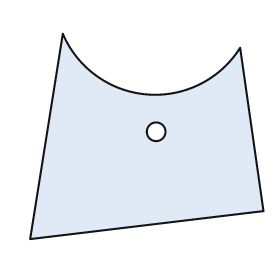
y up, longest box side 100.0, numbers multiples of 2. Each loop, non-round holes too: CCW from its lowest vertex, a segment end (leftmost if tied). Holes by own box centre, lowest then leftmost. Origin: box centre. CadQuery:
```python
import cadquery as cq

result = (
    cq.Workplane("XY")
    .moveTo(-50.0, -44.0)
    .lineTo(50.0, -32.0)
    .lineTo(40.0, 38.0)
    .threePointArc((0.0, 18.0), (-36.0, 44.0))
    .close()
    .moveTo(4.0, 2.0)
    .circle(4.0)
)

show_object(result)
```